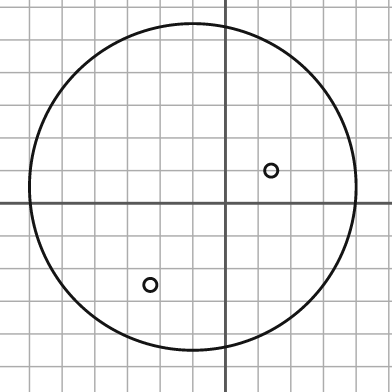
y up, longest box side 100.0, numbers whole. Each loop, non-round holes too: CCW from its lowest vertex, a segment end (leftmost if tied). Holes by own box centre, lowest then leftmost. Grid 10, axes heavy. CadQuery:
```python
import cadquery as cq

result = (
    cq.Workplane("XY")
    .moveTo(-10.0, 5.0)
    .circle(50.0)
    .moveTo(-23.0, -25.0)
    .circle(2.0)
    .moveTo(14.0, 10.0)
    .circle(2.0)
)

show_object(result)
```